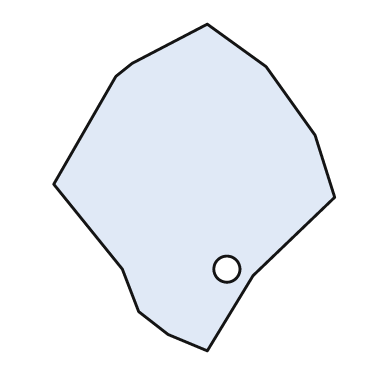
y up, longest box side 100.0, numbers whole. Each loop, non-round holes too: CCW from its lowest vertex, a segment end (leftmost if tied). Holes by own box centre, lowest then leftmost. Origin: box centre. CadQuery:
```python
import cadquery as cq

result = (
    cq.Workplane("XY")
    .moveTo(4.0, -50.0)
    .lineTo(18.0, -27.0)
    .lineTo(43.0, -3.0)
    .lineTo(37.0, 16.0)
    .lineTo(22.0, 37.0)
    .lineTo(4.0, 50.0)
    .lineTo(-19.0, 38.0)
    .lineTo(-24.0, 34.0)
    .lineTo(-43.0, 1.0)
    .lineTo(-22.0, -25.0)
    .lineTo(-17.0, -38.0)
    .lineTo(-8.0, -45.0)
    .close()
    .moveTo(10.0, -25.0)
    .circle(4.0)
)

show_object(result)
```